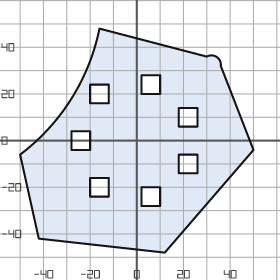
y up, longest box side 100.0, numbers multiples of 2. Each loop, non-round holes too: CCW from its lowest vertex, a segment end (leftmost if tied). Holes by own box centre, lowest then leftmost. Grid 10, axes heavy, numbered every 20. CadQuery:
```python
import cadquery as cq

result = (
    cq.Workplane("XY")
    .moveTo(12.0, -48.0)
    .lineTo(50.0, -4.0)
    .lineTo(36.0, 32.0)
    .threePointArc((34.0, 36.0), (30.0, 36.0))
    .lineTo(-16.0, 48.0)
    .threePointArc((-28.0, 18.0), (-50.0, -6.0))
    .lineTo(-42.0, -42.0)
    .close()
    .moveTo(2.0, -28.0)
    .lineTo(10.0, -28.0)
    .lineTo(10.0, -20.0)
    .lineTo(2.0, -20.0)
    .close()
    .moveTo(-20.0, -24.0)
    .lineTo(-12.0, -24.0)
    .lineTo(-12.0, -16.0)
    .lineTo(-20.0, -16.0)
    .close()
    .moveTo(18.0, -14.0)
    .lineTo(26.0, -14.0)
    .lineTo(26.0, -6.0)
    .lineTo(18.0, -6.0)
    .close()
    .moveTo(-28.0, -4.0)
    .lineTo(-20.0, -4.0)
    .lineTo(-20.0, 4.0)
    .lineTo(-28.0, 4.0)
    .close()
    .moveTo(18.0, 6.0)
    .lineTo(26.0, 6.0)
    .lineTo(26.0, 14.0)
    .lineTo(18.0, 14.0)
    .close()
    .moveTo(-20.0, 16.0)
    .lineTo(-12.0, 16.0)
    .lineTo(-12.0, 24.0)
    .lineTo(-20.0, 24.0)
    .close()
    .moveTo(2.0, 20.0)
    .lineTo(10.0, 20.0)
    .lineTo(10.0, 28.0)
    .lineTo(2.0, 28.0)
    .close()
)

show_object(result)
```